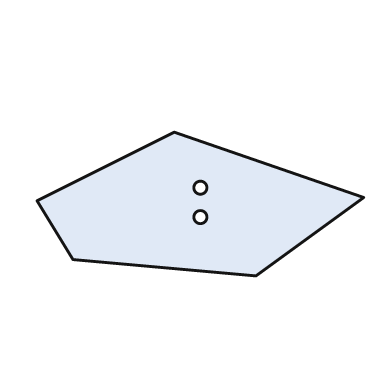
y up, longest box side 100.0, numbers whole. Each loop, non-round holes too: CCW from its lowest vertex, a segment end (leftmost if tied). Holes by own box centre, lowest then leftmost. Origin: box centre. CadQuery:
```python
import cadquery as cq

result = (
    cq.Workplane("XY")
    .moveTo(17.0, -22.0)
    .lineTo(50.0, 2.0)
    .lineTo(-8.0, 22.0)
    .lineTo(-50.0, 1.0)
    .lineTo(-39.0, -17.0)
    .close()
    .moveTo(0.0, -4.0)
    .circle(2.0)
    .moveTo(0.0, 5.0)
    .circle(2.0)
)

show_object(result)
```